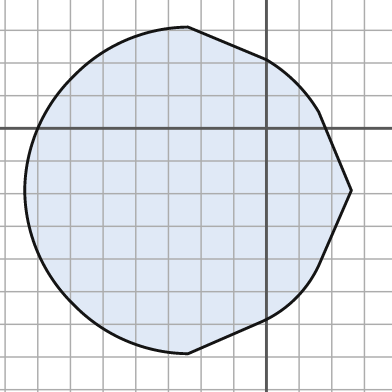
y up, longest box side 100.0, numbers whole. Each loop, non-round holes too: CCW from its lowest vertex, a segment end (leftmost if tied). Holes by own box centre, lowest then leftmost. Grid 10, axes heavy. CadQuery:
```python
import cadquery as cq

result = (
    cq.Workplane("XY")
    .moveTo(-24.0, -69.0)
    .lineTo(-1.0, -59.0)
    .threePointArc((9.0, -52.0), (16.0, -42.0))
    .lineTo(26.0, -19.0)
    .lineTo(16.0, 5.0)
    .threePointArc((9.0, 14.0), (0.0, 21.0))
    .lineTo(-24.0, 31.0)
    .threePointArc((-43.0, 27.0), (-59.0, 16.0))
    .threePointArc((-70.0, 0.0), (-74.0, -19.0))
    .threePointArc((-70.0, -38.0), (-59.0, -54.0))
    .threePointArc((-43.0, -65.0), (-24.0, -69.0))
    .close()
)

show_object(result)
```